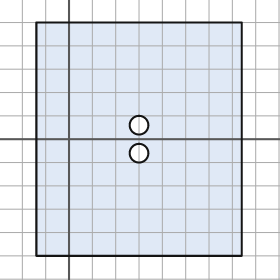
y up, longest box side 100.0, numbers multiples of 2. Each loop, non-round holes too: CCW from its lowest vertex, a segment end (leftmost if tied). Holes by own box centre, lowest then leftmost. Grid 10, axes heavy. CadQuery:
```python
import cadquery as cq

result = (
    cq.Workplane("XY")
    .moveTo(-14.0, -50.0)
    .lineTo(74.0, -50.0)
    .lineTo(74.0, 50.0)
    .lineTo(-14.0, 50.0)
    .close()
    .moveTo(30.0, -6.0)
    .circle(4.0)
    .moveTo(30.0, 6.0)
    .circle(4.0)
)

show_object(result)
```